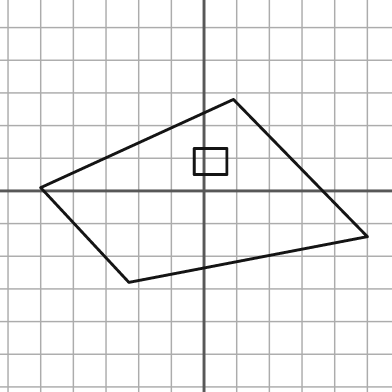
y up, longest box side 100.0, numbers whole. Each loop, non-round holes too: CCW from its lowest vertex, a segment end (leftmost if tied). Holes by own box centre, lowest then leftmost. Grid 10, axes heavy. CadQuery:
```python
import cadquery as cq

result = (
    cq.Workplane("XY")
    .moveTo(-23.0, -28.0)
    .lineTo(50.0, -14.0)
    .lineTo(9.0, 28.0)
    .lineTo(-50.0, 1.0)
    .close()
    .moveTo(-3.0, 5.0)
    .lineTo(7.0, 5.0)
    .lineTo(7.0, 13.0)
    .lineTo(-3.0, 13.0)
    .close()
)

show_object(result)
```